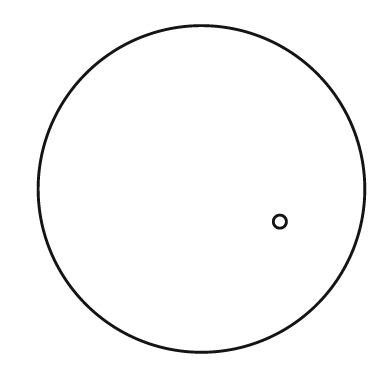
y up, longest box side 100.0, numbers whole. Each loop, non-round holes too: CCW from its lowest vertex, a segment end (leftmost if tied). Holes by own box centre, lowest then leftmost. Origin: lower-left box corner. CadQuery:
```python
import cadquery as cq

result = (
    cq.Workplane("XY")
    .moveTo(50.0, 50.0)
    .circle(50.0)
    .moveTo(74.0, 40.0)
    .circle(2.0)
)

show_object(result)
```